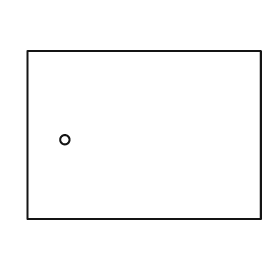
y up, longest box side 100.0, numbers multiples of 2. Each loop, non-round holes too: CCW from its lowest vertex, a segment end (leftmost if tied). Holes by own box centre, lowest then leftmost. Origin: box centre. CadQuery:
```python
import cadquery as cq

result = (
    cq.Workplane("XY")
    .moveTo(-50.0, -36.0)
    .lineTo(50.0, -36.0)
    .lineTo(50.0, 36.0)
    .lineTo(-50.0, 36.0)
    .close()
    .moveTo(-34.0, -2.0)
    .circle(2.0)
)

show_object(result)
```